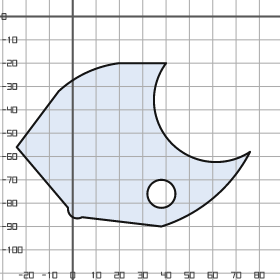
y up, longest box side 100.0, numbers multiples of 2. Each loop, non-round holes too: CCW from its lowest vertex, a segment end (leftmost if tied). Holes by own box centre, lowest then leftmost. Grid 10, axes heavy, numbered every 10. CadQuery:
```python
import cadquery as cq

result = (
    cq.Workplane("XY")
    .moveTo(38.0, -90.0)
    .threePointArc((60.0, -78.0), (76.0, -58.0))
    .threePointArc((42.0, -54.0), (40.0, -20.0))
    .lineTo(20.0, -20.0)
    .threePointArc((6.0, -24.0), (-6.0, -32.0))
    .lineTo(-24.0, -56.0)
    .lineTo(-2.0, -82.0)
    .threePointArc((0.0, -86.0), (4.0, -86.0))
    .close()
    .moveTo(38.0, -76.0)
    .circle(6.0)
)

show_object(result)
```